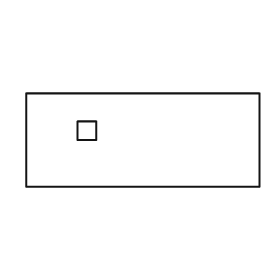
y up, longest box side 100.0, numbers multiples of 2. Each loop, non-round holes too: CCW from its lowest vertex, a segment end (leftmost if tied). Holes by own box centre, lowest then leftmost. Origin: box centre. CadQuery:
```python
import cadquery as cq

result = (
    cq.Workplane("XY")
    .moveTo(-50.0, -20.0)
    .lineTo(50.0, -20.0)
    .lineTo(50.0, 20.0)
    .lineTo(-50.0, 20.0)
    .close()
    .moveTo(-28.0, 0.0)
    .lineTo(-20.0, 0.0)
    .lineTo(-20.0, 8.0)
    .lineTo(-28.0, 8.0)
    .close()
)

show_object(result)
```